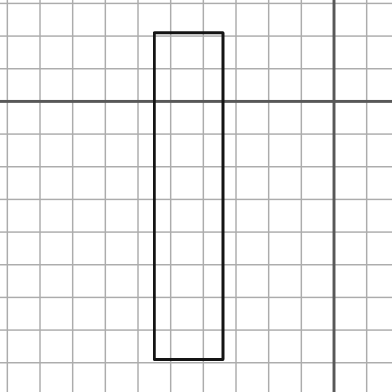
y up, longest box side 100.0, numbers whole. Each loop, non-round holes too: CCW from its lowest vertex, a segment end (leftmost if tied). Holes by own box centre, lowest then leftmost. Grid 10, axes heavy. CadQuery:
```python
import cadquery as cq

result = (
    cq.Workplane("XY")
    .moveTo(-55.0, -79.0)
    .lineTo(-34.0, -79.0)
    .lineTo(-34.0, 21.0)
    .lineTo(-55.0, 21.0)
    .close()
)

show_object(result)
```